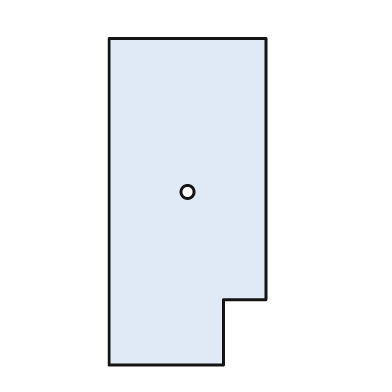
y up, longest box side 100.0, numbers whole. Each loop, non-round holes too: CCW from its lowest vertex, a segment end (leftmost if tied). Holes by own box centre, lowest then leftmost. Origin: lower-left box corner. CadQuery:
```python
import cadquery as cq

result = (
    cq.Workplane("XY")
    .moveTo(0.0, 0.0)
    .lineTo(35.0, 0.0)
    .lineTo(35.0, 20.0)
    .lineTo(48.0, 20.0)
    .lineTo(48.0, 100.0)
    .lineTo(0.0, 100.0)
    .close()
    .moveTo(24.0, 53.0)
    .circle(2.0)
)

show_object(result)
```